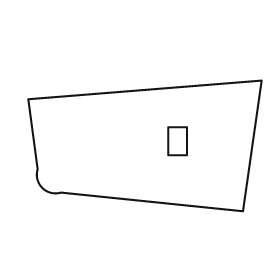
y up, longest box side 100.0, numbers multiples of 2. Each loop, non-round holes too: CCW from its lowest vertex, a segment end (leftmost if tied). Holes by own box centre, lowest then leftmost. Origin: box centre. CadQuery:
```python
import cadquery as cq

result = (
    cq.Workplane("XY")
    .moveTo(42.0, -28.0)
    .lineTo(50.0, 28.0)
    .lineTo(-50.0, 20.0)
    .lineTo(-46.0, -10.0)
    .threePointArc((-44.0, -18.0), (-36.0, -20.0))
    .close()
    .moveTo(10.0, -4.0)
    .lineTo(18.0, -4.0)
    .lineTo(18.0, 8.0)
    .lineTo(10.0, 8.0)
    .close()
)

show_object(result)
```